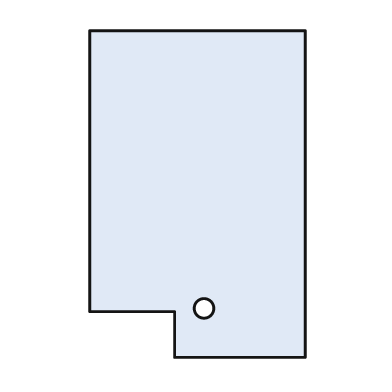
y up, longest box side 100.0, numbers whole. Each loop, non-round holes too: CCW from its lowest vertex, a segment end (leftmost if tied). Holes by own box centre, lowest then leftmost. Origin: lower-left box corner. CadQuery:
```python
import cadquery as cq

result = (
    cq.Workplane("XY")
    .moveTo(26.0, 0.0)
    .lineTo(66.0, 0.0)
    .lineTo(66.0, 100.0)
    .lineTo(0.0, 100.0)
    .lineTo(0.0, 14.0)
    .lineTo(26.0, 14.0)
    .close()
    .moveTo(35.0, 15.0)
    .circle(3.0)
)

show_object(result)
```